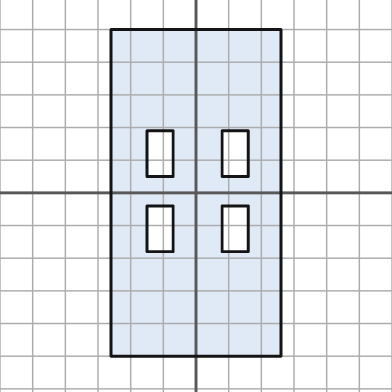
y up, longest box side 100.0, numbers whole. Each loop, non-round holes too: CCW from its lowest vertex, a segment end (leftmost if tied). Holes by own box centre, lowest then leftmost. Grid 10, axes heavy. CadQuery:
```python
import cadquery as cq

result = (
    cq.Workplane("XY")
    .moveTo(-26.0, -50.0)
    .lineTo(26.0, -50.0)
    .lineTo(26.0, 50.0)
    .lineTo(-26.0, 50.0)
    .close()
    .moveTo(-15.0, -18.0)
    .lineTo(-7.0, -18.0)
    .lineTo(-7.0, -4.0)
    .lineTo(-15.0, -4.0)
    .close()
    .moveTo(8.0, -18.0)
    .lineTo(16.0, -18.0)
    .lineTo(16.0, -4.0)
    .lineTo(8.0, -4.0)
    .close()
    .moveTo(-15.0, 5.0)
    .lineTo(-7.0, 5.0)
    .lineTo(-7.0, 19.0)
    .lineTo(-15.0, 19.0)
    .close()
    .moveTo(8.0, 5.0)
    .lineTo(16.0, 5.0)
    .lineTo(16.0, 19.0)
    .lineTo(8.0, 19.0)
    .close()
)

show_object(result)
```